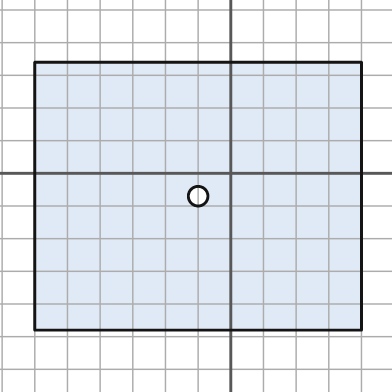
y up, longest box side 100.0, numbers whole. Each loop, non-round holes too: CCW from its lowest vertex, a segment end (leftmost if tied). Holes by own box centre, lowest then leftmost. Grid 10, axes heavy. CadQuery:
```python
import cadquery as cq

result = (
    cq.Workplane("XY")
    .moveTo(-60.0, -48.0)
    .lineTo(40.0, -48.0)
    .lineTo(40.0, 34.0)
    .lineTo(-60.0, 34.0)
    .close()
    .moveTo(-10.0, -7.0)
    .circle(3.0)
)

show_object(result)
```